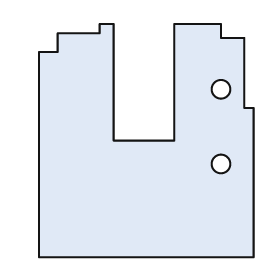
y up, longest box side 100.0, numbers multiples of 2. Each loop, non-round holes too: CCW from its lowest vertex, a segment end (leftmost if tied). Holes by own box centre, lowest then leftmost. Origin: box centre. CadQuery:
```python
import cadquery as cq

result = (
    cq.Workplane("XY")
    .moveTo(-46.0, -50.0)
    .lineTo(46.0, -50.0)
    .lineTo(46.0, 14.0)
    .lineTo(42.0, 14.0)
    .lineTo(42.0, 44.0)
    .lineTo(32.0, 44.0)
    .lineTo(32.0, 50.0)
    .lineTo(12.0, 50.0)
    .lineTo(12.0, 0.0)
    .lineTo(-14.0, 0.0)
    .lineTo(-14.0, 50.0)
    .lineTo(-20.0, 50.0)
    .lineTo(-20.0, 46.0)
    .lineTo(-38.0, 46.0)
    .lineTo(-38.0, 38.0)
    .lineTo(-46.0, 38.0)
    .close()
    .moveTo(32.0, -10.0)
    .circle(4.0)
    .moveTo(32.0, 22.0)
    .circle(4.0)
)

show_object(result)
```